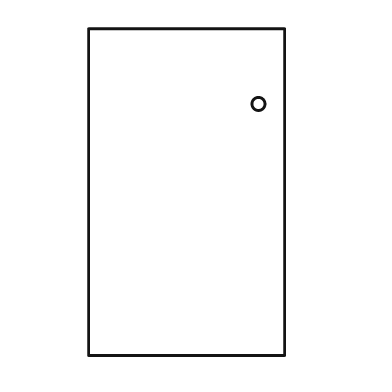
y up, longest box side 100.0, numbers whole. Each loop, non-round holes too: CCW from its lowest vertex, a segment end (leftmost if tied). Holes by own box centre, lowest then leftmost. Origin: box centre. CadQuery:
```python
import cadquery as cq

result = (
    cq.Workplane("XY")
    .moveTo(-30.0, -50.0)
    .lineTo(30.0, -50.0)
    .lineTo(30.0, 50.0)
    .lineTo(-30.0, 50.0)
    .close()
    .moveTo(22.0, 27.0)
    .circle(2.0)
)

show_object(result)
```